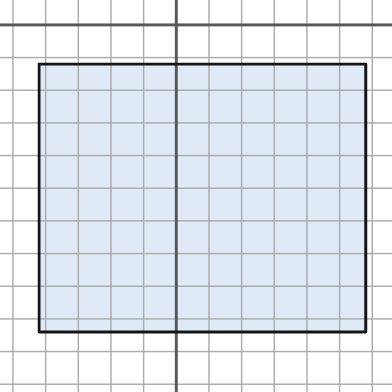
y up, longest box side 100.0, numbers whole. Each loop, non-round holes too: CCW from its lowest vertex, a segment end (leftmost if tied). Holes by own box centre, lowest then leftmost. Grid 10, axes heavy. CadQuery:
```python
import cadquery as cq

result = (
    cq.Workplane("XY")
    .moveTo(-42.0, -94.0)
    .lineTo(58.0, -94.0)
    .lineTo(58.0, -12.0)
    .lineTo(-42.0, -12.0)
    .close()
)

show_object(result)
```